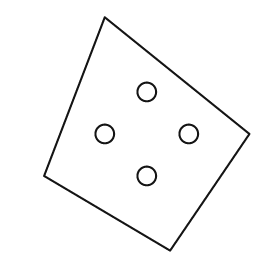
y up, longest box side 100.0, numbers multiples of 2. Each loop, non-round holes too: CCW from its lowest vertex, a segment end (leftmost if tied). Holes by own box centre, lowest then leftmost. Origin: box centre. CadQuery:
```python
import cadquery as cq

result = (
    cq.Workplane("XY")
    .moveTo(10.0, -50.0)
    .lineTo(44.0, 0.0)
    .lineTo(-18.0, 50.0)
    .lineTo(-44.0, -18.0)
    .close()
    .moveTo(0.0, -18.0)
    .circle(4.0)
    .moveTo(-18.0, 0.0)
    .circle(4.0)
    .moveTo(18.0, 0.0)
    .circle(4.0)
    .moveTo(0.0, 18.0)
    .circle(4.0)
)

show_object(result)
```